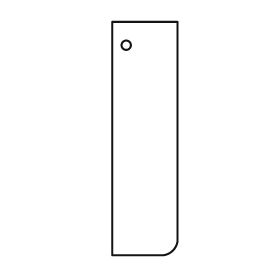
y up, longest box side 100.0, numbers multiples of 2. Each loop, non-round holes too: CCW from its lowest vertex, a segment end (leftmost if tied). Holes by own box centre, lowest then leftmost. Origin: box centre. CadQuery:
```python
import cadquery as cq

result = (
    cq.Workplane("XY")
    .moveTo(-14.0, -50.0)
    .lineTo(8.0, -50.0)
    .threePointArc((12.0, -48.0), (14.0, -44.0))
    .lineTo(14.0, 50.0)
    .lineTo(-14.0, 50.0)
    .close()
    .moveTo(-8.0, 40.0)
    .circle(2.0)
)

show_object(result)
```